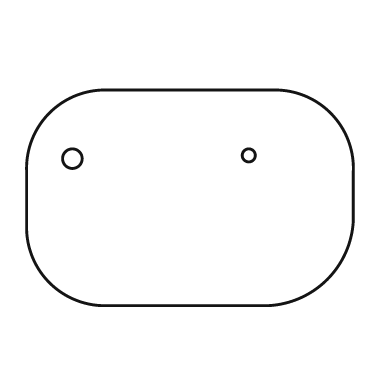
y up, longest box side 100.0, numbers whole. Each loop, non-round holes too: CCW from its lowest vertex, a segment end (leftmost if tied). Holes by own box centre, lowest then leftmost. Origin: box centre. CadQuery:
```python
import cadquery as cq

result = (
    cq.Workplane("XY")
    .moveTo(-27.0, -33.0)
    .lineTo(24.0, -33.0)
    .threePointArc((42.0, -25.0), (50.0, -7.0))
    .lineTo(50.0, 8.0)
    .threePointArc((43.0, 26.0), (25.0, 33.0))
    .lineTo(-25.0, 33.0)
    .threePointArc((-43.0, 26.0), (-50.0, 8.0))
    .lineTo(-50.0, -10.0)
    .threePointArc((-43.0, -26.0), (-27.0, -33.0))
    .close()
    .moveTo(-36.0, 12.0)
    .circle(3.0)
    .moveTo(18.0, 13.0)
    .circle(2.0)
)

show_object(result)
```